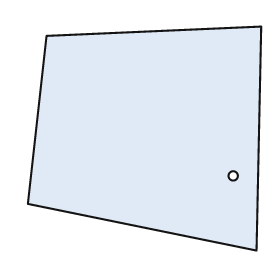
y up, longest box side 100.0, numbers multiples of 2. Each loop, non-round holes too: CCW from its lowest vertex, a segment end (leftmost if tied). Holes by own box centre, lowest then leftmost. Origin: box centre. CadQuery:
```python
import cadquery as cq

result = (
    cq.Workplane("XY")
    .moveTo(48.0, -48.0)
    .lineTo(50.0, 48.0)
    .lineTo(-42.0, 44.0)
    .lineTo(-50.0, -28.0)
    .close()
    .moveTo(38.0, -16.0)
    .circle(2.0)
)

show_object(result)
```